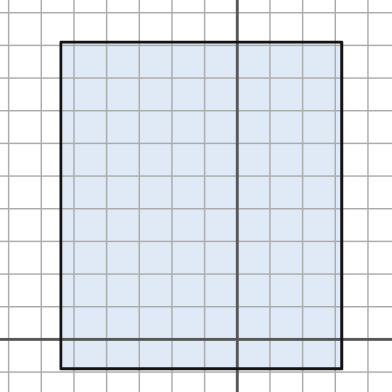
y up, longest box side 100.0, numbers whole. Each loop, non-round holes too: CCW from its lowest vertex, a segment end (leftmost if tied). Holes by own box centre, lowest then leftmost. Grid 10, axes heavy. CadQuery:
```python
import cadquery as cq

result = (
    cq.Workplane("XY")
    .moveTo(-54.0, -9.0)
    .lineTo(32.0, -9.0)
    .lineTo(32.0, 91.0)
    .lineTo(-54.0, 91.0)
    .close()
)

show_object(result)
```